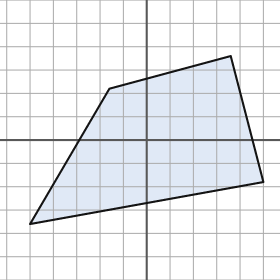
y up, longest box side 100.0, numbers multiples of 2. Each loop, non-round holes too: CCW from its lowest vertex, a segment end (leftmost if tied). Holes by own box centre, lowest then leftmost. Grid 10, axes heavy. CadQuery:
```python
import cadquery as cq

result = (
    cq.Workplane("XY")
    .moveTo(-50.0, -36.0)
    .lineTo(50.0, -18.0)
    .lineTo(36.0, 36.0)
    .lineTo(-16.0, 22.0)
    .close()
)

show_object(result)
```